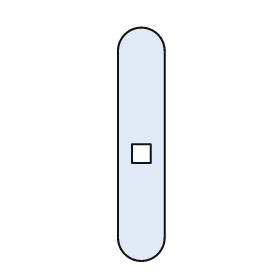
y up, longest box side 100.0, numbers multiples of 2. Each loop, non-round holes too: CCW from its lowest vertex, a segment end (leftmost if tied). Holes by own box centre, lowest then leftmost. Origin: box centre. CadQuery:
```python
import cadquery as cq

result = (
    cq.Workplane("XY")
    .moveTo(-10.0, -40.0)
    .threePointArc((0.0, -50.0), (10.0, -40.0))
    .lineTo(10.0, 40.0)
    .threePointArc((0.0, 50.0), (-10.0, 40.0))
    .close()
    .moveTo(-4.0, -8.0)
    .lineTo(4.0, -8.0)
    .lineTo(4.0, 0.0)
    .lineTo(-4.0, 0.0)
    .close()
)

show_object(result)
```